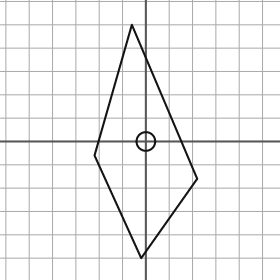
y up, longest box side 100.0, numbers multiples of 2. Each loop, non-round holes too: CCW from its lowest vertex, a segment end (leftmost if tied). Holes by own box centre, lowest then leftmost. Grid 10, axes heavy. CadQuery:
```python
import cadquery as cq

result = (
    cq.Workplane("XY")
    .moveTo(-2.0, -50.0)
    .lineTo(22.0, -16.0)
    .lineTo(-6.0, 50.0)
    .lineTo(-22.0, -6.0)
    .close()
    .moveTo(0.0, 0.0)
    .circle(4.0)
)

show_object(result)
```